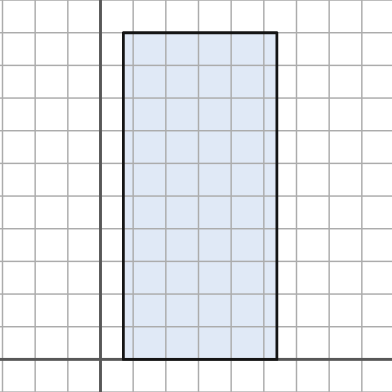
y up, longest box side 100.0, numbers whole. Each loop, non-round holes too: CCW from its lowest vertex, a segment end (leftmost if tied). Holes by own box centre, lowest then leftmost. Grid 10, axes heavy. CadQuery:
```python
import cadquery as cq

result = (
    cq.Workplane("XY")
    .moveTo(7.0, 0.0)
    .lineTo(54.0, 0.0)
    .lineTo(54.0, 100.0)
    .lineTo(7.0, 100.0)
    .close()
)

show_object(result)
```